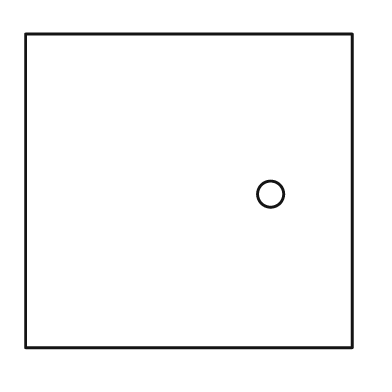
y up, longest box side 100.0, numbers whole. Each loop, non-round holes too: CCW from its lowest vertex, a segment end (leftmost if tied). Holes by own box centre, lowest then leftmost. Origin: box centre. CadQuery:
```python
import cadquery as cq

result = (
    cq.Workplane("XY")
    .moveTo(-50.0, -48.0)
    .lineTo(50.0, -48.0)
    .lineTo(50.0, 48.0)
    .lineTo(-50.0, 48.0)
    .close()
    .moveTo(25.0, -1.0)
    .circle(4.0)
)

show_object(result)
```